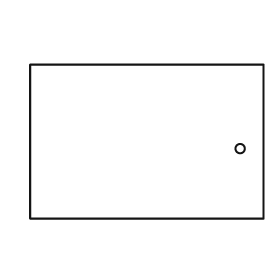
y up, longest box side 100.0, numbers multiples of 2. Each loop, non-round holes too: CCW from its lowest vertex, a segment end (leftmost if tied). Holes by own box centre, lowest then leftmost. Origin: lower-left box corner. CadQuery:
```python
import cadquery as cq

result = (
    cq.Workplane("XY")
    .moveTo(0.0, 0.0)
    .lineTo(100.0, 0.0)
    .lineTo(100.0, 66.0)
    .lineTo(0.0, 66.0)
    .close()
    .moveTo(90.0, 30.0)
    .circle(2.0)
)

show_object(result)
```